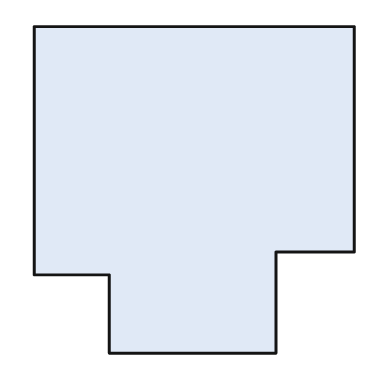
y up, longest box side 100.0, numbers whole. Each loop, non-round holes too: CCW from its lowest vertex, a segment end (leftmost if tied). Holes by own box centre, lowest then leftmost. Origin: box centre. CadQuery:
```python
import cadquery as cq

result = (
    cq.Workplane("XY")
    .moveTo(-26.0, -50.0)
    .lineTo(25.0, -50.0)
    .lineTo(25.0, -19.0)
    .lineTo(49.0, -19.0)
    .lineTo(49.0, 50.0)
    .lineTo(-49.0, 50.0)
    .lineTo(-49.0, -26.0)
    .lineTo(-26.0, -26.0)
    .close()
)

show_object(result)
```